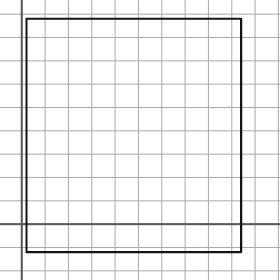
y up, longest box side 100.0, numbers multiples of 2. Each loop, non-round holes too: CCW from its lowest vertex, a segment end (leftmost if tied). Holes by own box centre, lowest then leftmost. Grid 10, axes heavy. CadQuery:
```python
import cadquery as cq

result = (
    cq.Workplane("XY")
    .moveTo(2.0, -12.0)
    .lineTo(94.0, -12.0)
    .lineTo(94.0, 88.0)
    .lineTo(2.0, 88.0)
    .close()
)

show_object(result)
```